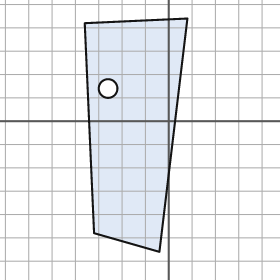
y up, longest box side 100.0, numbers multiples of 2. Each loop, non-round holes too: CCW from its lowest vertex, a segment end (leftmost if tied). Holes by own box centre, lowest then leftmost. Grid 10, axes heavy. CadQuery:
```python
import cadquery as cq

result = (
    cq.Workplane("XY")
    .moveTo(-4.0, -56.0)
    .lineTo(8.0, 44.0)
    .lineTo(-36.0, 42.0)
    .lineTo(-32.0, -48.0)
    .close()
    .moveTo(-26.0, 14.0)
    .circle(4.0)
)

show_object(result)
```